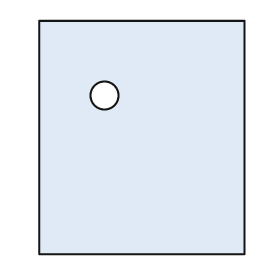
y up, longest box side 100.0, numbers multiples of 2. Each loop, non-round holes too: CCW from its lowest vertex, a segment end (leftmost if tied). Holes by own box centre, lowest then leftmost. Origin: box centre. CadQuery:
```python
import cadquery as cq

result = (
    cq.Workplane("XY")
    .moveTo(-44.0, -50.0)
    .lineTo(44.0, -50.0)
    .lineTo(44.0, 50.0)
    .lineTo(-44.0, 50.0)
    .close()
    .moveTo(-16.0, 18.0)
    .circle(6.0)
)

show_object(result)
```